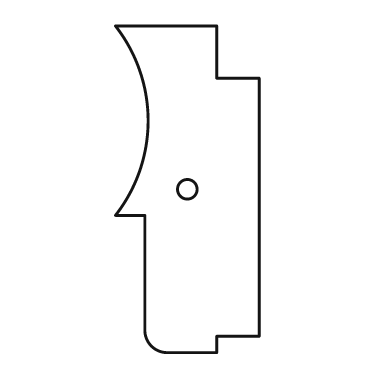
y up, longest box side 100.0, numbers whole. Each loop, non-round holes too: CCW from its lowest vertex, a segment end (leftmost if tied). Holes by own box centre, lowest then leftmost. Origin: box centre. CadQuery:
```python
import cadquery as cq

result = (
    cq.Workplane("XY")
    .moveTo(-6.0, -50.0)
    .lineTo(9.0, -50.0)
    .lineTo(9.0, -45.0)
    .lineTo(22.0, -45.0)
    .lineTo(22.0, 34.0)
    .lineTo(9.0, 34.0)
    .lineTo(9.0, 50.0)
    .lineTo(-22.0, 50.0)
    .threePointArc((-12.0, 21.0), (-22.0, -8.0))
    .lineTo(-13.0, -8.0)
    .lineTo(-13.0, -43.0)
    .threePointArc((-11.0, -48.0), (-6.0, -50.0))
    .close()
    .moveTo(0.0, 0.0)
    .circle(3.0)
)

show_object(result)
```